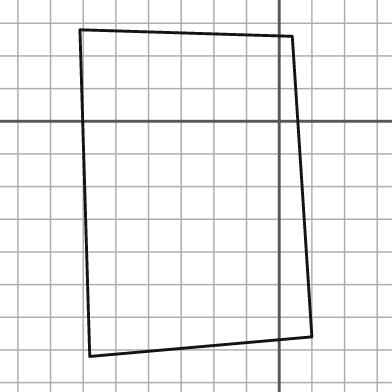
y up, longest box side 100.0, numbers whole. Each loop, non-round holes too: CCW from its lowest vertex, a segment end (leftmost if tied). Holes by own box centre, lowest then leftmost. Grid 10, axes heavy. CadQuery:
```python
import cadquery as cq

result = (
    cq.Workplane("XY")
    .moveTo(-58.0, -72.0)
    .lineTo(10.0, -66.0)
    .lineTo(4.0, 26.0)
    .lineTo(-61.0, 28.0)
    .close()
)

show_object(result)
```